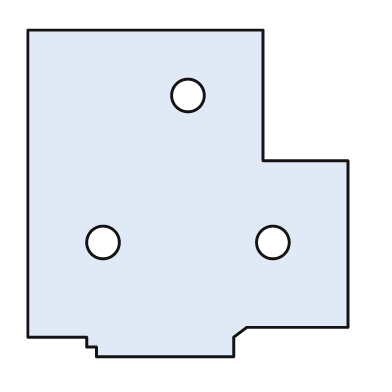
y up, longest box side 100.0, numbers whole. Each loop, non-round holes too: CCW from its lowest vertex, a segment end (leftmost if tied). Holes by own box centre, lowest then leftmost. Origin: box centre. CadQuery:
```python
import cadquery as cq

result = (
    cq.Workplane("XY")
    .moveTo(-28.0, -50.0)
    .lineTo(14.0, -50.0)
    .lineTo(14.0, -44.0)
    .lineTo(18.0, -41.0)
    .lineTo(49.0, -41.0)
    .lineTo(49.0, 10.0)
    .lineTo(23.0, 10.0)
    .lineTo(23.0, 50.0)
    .lineTo(-49.0, 50.0)
    .lineTo(-49.0, -44.0)
    .lineTo(-31.0, -44.0)
    .lineTo(-31.0, -47.0)
    .lineTo(-28.0, -47.0)
    .close()
    .moveTo(-26.0, -15.0)
    .circle(5.0)
    .moveTo(26.0, -15.0)
    .circle(5.0)
    .moveTo(0.0, 30.0)
    .circle(5.0)
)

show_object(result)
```